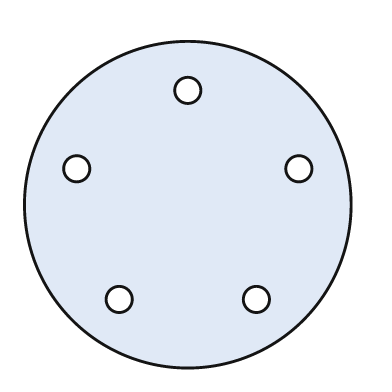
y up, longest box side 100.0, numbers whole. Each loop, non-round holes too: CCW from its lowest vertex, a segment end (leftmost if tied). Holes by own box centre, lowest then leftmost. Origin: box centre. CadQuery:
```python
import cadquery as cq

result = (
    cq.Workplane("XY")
    .moveTo(0.0, 0.0)
    .circle(50.0)
    .moveTo(-21.0, -29.0)
    .circle(4.0)
    .moveTo(21.0, -29.0)
    .circle(4.0)
    .moveTo(-34.0, 11.0)
    .circle(4.0)
    .moveTo(34.0, 11.0)
    .circle(4.0)
    .moveTo(0.0, 35.0)
    .circle(4.0)
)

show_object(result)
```